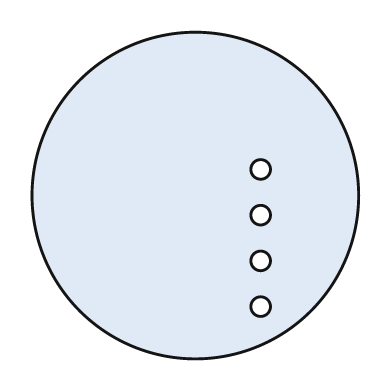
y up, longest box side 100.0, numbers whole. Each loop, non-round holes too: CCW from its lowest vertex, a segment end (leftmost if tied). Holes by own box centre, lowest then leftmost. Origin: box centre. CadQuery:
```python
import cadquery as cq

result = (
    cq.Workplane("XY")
    .moveTo(0.0, 0.0)
    .circle(50.0)
    .moveTo(20.0, -34.0)
    .circle(3.0)
    .moveTo(20.0, -20.0)
    .circle(3.0)
    .moveTo(20.0, -6.0)
    .circle(3.0)
    .moveTo(20.0, 8.0)
    .circle(3.0)
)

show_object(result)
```